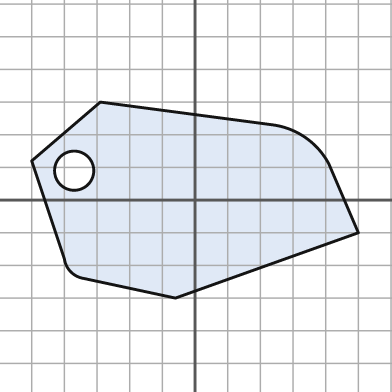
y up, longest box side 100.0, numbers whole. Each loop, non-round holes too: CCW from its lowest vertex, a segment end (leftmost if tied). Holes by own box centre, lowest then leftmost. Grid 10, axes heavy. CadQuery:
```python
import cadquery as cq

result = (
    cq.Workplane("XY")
    .moveTo(-6.0, -30.0)
    .lineTo(50.0, -10.0)
    .lineTo(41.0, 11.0)
    .threePointArc((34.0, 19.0), (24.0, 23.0))
    .lineTo(-29.0, 30.0)
    .lineTo(-50.0, 12.0)
    .lineTo(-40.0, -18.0)
    .threePointArc((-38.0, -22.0), (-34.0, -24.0))
    .close()
    .moveTo(-37.0, 9.0)
    .circle(6.0)
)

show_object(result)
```